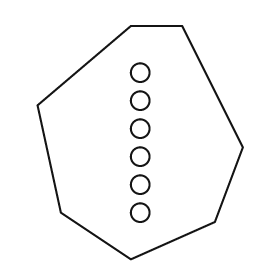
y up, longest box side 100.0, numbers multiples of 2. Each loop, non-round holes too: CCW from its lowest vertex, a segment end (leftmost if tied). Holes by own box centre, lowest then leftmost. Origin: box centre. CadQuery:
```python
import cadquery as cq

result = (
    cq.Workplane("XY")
    .moveTo(-4.0, -50.0)
    .lineTo(32.0, -34.0)
    .lineTo(44.0, -2.0)
    .lineTo(18.0, 50.0)
    .lineTo(-4.0, 50.0)
    .lineTo(-44.0, 16.0)
    .lineTo(-34.0, -30.0)
    .close()
    .moveTo(0.0, -30.0)
    .circle(4.0)
    .moveTo(0.0, -18.0)
    .circle(4.0)
    .moveTo(0.0, -6.0)
    .circle(4.0)
    .moveTo(0.0, 6.0)
    .circle(4.0)
    .moveTo(0.0, 18.0)
    .circle(4.0)
    .moveTo(0.0, 30.0)
    .circle(4.0)
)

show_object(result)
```